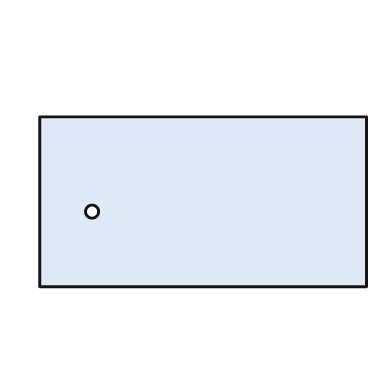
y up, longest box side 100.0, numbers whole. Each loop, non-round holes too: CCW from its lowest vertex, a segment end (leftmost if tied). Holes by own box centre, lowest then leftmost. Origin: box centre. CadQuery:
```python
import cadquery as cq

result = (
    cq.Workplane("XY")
    .moveTo(-50.0, -26.0)
    .lineTo(50.0, -26.0)
    .lineTo(50.0, 26.0)
    .lineTo(-50.0, 26.0)
    .close()
    .moveTo(-34.0, -3.0)
    .circle(2.0)
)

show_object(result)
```